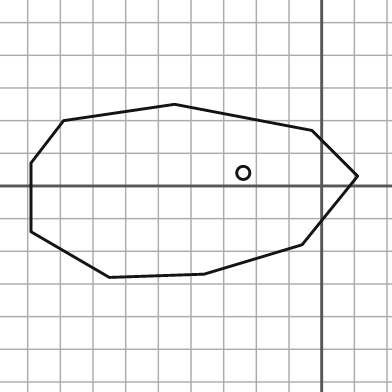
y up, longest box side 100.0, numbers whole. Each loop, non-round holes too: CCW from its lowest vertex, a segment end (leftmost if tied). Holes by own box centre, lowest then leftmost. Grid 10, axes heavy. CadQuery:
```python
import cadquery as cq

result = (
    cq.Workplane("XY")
    .moveTo(-65.0, -28.0)
    .lineTo(-36.0, -27.0)
    .lineTo(-6.0, -18.0)
    .lineTo(11.0, 3.0)
    .lineTo(-3.0, 17.0)
    .lineTo(-45.0, 25.0)
    .lineTo(-79.0, 20.0)
    .lineTo(-89.0, 7.0)
    .lineTo(-89.0, -14.0)
    .close()
    .moveTo(-24.0, 4.0)
    .circle(2.0)
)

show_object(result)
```